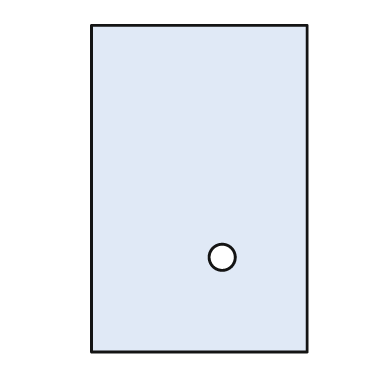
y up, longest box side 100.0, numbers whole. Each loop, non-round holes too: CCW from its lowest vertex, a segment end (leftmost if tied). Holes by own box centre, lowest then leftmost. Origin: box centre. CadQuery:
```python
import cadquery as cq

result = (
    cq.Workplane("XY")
    .moveTo(-33.0, -50.0)
    .lineTo(33.0, -50.0)
    .lineTo(33.0, 50.0)
    .lineTo(-33.0, 50.0)
    .close()
    .moveTo(7.0, -21.0)
    .circle(4.0)
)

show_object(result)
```